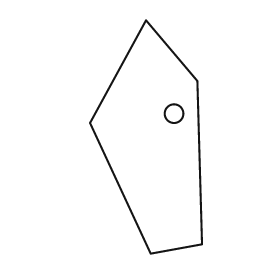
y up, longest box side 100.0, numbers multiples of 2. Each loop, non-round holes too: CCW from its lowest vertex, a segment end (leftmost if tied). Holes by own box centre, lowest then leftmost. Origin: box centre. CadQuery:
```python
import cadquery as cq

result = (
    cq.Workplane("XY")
    .moveTo(2.0, -50.0)
    .lineTo(24.0, -46.0)
    .lineTo(22.0, 24.0)
    .lineTo(0.0, 50.0)
    .lineTo(-24.0, 6.0)
    .close()
    .moveTo(12.0, 10.0)
    .circle(4.0)
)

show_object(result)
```